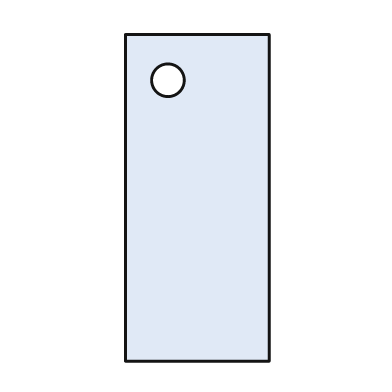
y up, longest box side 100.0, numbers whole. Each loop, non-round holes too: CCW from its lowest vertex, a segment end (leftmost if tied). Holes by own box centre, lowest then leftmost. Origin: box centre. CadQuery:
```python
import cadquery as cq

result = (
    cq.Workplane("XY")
    .moveTo(-22.0, -50.0)
    .lineTo(22.0, -50.0)
    .lineTo(22.0, 50.0)
    .lineTo(-22.0, 50.0)
    .close()
    .moveTo(-9.0, 36.0)
    .circle(5.0)
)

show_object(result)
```